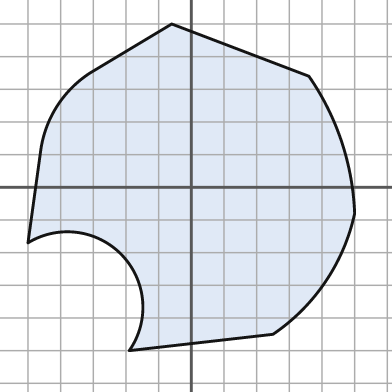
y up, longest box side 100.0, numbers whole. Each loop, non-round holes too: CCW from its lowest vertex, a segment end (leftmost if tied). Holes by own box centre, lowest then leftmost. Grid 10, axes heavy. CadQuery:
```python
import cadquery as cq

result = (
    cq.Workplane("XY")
    .moveTo(-19.0, -50.0)
    .lineTo(25.0, -45.0)
    .threePointArc((41.0, -29.0), (50.0, -8.0))
    .threePointArc((46.0, 14.0), (36.0, 34.0))
    .lineTo(-6.0, 50.0)
    .lineTo(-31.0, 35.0)
    .threePointArc((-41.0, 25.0), (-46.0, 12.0))
    .lineTo(-50.0, -17.0)
    .threePointArc((-21.0, -21.0), (-19.0, -50.0))
    .close()
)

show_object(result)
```